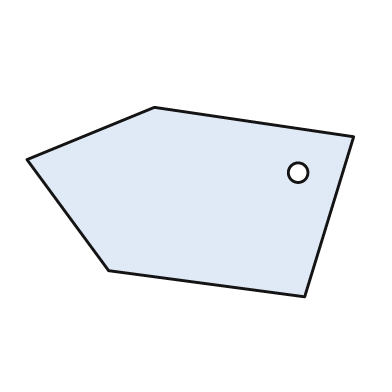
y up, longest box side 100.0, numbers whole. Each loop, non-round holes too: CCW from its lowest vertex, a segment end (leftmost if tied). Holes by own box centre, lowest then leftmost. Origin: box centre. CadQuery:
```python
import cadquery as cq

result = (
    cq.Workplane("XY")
    .moveTo(35.0, -29.0)
    .lineTo(50.0, 20.0)
    .lineTo(-11.0, 29.0)
    .lineTo(-50.0, 13.0)
    .lineTo(-25.0, -21.0)
    .close()
    .moveTo(33.0, 9.0)
    .circle(3.0)
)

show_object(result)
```